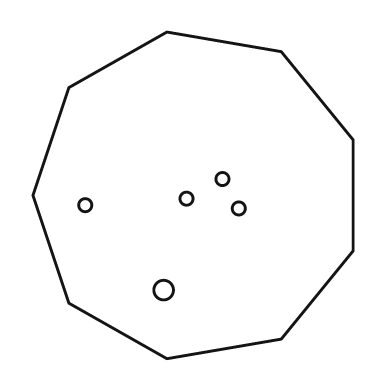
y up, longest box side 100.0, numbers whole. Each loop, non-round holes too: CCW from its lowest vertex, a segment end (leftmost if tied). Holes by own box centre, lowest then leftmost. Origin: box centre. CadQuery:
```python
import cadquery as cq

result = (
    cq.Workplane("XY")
    .moveTo(-8.0, -50.0)
    .lineTo(27.0, -44.0)
    .lineTo(49.0, -17.0)
    .lineTo(49.0, 17.0)
    .lineTo(27.0, 44.0)
    .lineTo(-8.0, 50.0)
    .lineTo(-38.0, 33.0)
    .lineTo(-49.0, 0.0)
    .lineTo(-38.0, -33.0)
    .close()
    .moveTo(-9.0, -29.0)
    .circle(3.0)
    .moveTo(14.0, -4.0)
    .circle(2.0)
    .moveTo(-33.0, -3.0)
    .circle(2.0)
    .moveTo(-2.0, -1.0)
    .circle(2.0)
    .moveTo(9.0, 5.0)
    .circle(2.0)
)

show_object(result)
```